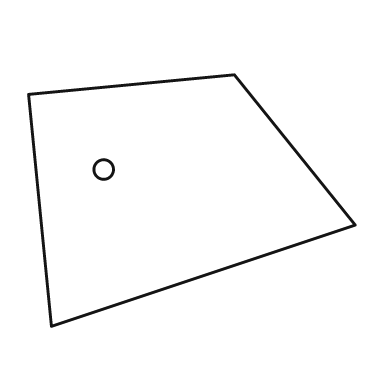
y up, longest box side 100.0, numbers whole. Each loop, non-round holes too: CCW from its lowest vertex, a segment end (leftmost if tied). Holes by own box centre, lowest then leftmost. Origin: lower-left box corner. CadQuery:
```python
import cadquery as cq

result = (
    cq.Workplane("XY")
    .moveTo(7.0, 0.0)
    .lineTo(100.0, 31.0)
    .lineTo(63.0, 77.0)
    .lineTo(0.0, 71.0)
    .close()
    .moveTo(23.0, 48.0)
    .circle(3.0)
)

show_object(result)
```